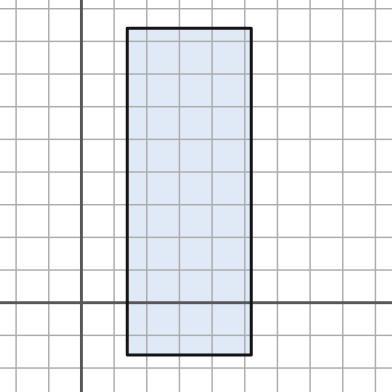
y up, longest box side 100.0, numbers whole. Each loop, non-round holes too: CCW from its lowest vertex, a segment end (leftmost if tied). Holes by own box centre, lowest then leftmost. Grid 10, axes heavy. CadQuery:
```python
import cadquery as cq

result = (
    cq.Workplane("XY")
    .moveTo(14.0, -16.0)
    .lineTo(52.0, -16.0)
    .lineTo(52.0, 84.0)
    .lineTo(14.0, 84.0)
    .close()
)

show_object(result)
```